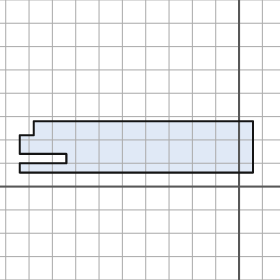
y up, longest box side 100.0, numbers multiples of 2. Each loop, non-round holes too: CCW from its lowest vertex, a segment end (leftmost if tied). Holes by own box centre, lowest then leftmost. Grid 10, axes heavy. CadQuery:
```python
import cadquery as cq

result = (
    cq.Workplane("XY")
    .moveTo(-94.0, 6.0)
    .lineTo(6.0, 6.0)
    .lineTo(6.0, 28.0)
    .lineTo(-88.0, 28.0)
    .lineTo(-88.0, 22.0)
    .lineTo(-94.0, 22.0)
    .lineTo(-94.0, 14.0)
    .lineTo(-74.0, 14.0)
    .lineTo(-74.0, 10.0)
    .lineTo(-94.0, 10.0)
    .close()
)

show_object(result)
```